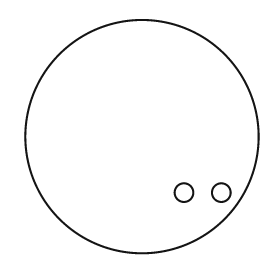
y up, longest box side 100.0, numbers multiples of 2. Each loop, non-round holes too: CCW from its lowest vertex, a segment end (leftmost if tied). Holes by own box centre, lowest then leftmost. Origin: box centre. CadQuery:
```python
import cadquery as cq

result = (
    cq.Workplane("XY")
    .moveTo(0.0, 0.0)
    .circle(50.0)
    .moveTo(18.0, -24.0)
    .circle(4.0)
    .moveTo(34.0, -24.0)
    .circle(4.0)
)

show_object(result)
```